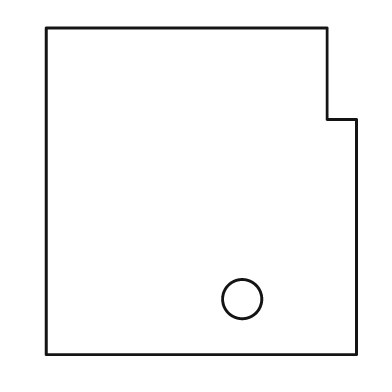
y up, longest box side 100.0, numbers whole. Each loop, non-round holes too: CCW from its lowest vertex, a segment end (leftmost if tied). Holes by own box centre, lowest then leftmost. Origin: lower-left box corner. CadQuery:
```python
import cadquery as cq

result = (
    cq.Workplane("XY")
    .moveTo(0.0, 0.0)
    .lineTo(95.0, 0.0)
    .lineTo(95.0, 72.0)
    .lineTo(86.0, 72.0)
    .lineTo(86.0, 100.0)
    .lineTo(0.0, 100.0)
    .close()
    .moveTo(60.0, 17.0)
    .circle(6.0)
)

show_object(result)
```